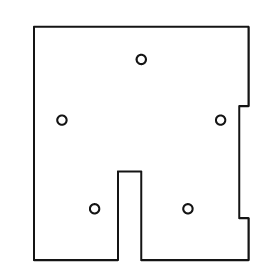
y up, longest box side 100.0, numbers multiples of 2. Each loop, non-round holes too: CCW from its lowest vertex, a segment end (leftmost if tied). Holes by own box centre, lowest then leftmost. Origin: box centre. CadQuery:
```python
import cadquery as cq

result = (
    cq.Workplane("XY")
    .moveTo(-46.0, -50.0)
    .lineTo(-10.0, -50.0)
    .lineTo(-10.0, -12.0)
    .lineTo(0.0, -12.0)
    .lineTo(0.0, -50.0)
    .lineTo(46.0, -50.0)
    .lineTo(46.0, -32.0)
    .lineTo(42.0, -32.0)
    .lineTo(42.0, 16.0)
    .lineTo(46.0, 16.0)
    .lineTo(46.0, 50.0)
    .lineTo(-46.0, 50.0)
    .close()
    .moveTo(-20.0, -28.0)
    .circle(2.0)
    .moveTo(20.0, -28.0)
    .circle(2.0)
    .moveTo(-34.0, 10.0)
    .circle(2.0)
    .moveTo(34.0, 10.0)
    .circle(2.0)
    .moveTo(0.0, 36.0)
    .circle(2.0)
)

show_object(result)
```